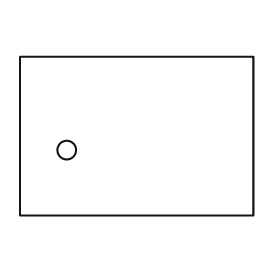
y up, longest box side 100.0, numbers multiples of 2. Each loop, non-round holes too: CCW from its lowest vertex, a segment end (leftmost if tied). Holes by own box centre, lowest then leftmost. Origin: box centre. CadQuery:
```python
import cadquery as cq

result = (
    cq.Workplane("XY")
    .moveTo(-50.0, -34.0)
    .lineTo(50.0, -34.0)
    .lineTo(50.0, 34.0)
    .lineTo(-50.0, 34.0)
    .close()
    .moveTo(-30.0, -6.0)
    .circle(4.0)
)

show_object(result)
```